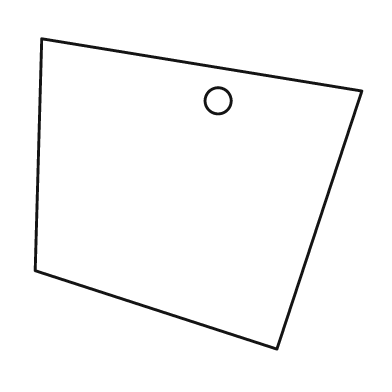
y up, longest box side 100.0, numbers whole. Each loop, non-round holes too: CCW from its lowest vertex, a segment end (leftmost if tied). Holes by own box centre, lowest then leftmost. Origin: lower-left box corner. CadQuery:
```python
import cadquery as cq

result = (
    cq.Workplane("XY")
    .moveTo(74.0, 0.0)
    .lineTo(100.0, 79.0)
    .lineTo(2.0, 95.0)
    .lineTo(0.0, 24.0)
    .close()
    .moveTo(56.0, 76.0)
    .circle(4.0)
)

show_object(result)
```